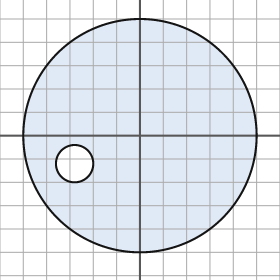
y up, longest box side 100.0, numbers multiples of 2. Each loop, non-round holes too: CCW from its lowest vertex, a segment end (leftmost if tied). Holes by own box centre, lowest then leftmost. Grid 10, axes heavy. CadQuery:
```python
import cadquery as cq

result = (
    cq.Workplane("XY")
    .moveTo(0.0, 0.0)
    .circle(50.0)
    .moveTo(-28.0, -12.0)
    .circle(8.0)
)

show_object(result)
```